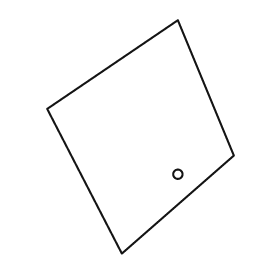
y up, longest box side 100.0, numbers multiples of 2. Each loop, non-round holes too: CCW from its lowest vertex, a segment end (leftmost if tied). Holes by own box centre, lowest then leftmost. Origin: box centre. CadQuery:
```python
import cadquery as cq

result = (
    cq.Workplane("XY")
    .moveTo(-8.0, -50.0)
    .lineTo(40.0, -8.0)
    .lineTo(16.0, 50.0)
    .lineTo(-40.0, 12.0)
    .close()
    .moveTo(16.0, -16.0)
    .circle(2.0)
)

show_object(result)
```